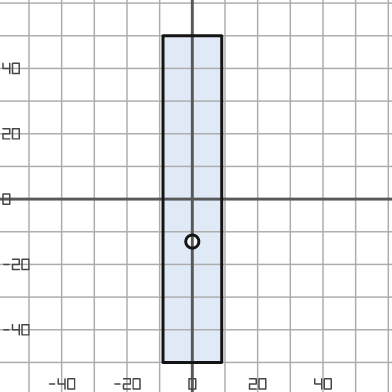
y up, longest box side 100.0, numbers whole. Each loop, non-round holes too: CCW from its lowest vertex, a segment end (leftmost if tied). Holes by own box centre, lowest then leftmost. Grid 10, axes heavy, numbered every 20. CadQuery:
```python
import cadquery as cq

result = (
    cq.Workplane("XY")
    .moveTo(-9.0, -50.0)
    .lineTo(9.0, -50.0)
    .lineTo(9.0, 50.0)
    .lineTo(-9.0, 50.0)
    .close()
    .moveTo(0.0, -13.0)
    .circle(2.0)
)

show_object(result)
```